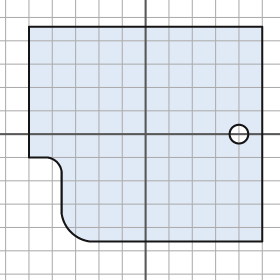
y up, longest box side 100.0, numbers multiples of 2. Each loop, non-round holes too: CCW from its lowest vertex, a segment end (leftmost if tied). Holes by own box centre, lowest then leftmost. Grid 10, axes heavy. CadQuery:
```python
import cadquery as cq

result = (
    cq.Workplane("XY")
    .moveTo(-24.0, -46.0)
    .lineTo(50.0, -46.0)
    .lineTo(50.0, 46.0)
    .lineTo(-50.0, 46.0)
    .lineTo(-50.0, -10.0)
    .lineTo(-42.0, -10.0)
    .threePointArc((-38.0, -12.0), (-36.0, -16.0))
    .lineTo(-36.0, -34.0)
    .threePointArc((-32.0, -42.0), (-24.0, -46.0))
    .close()
    .moveTo(40.0, 0.0)
    .circle(4.0)
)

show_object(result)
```